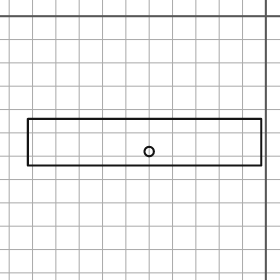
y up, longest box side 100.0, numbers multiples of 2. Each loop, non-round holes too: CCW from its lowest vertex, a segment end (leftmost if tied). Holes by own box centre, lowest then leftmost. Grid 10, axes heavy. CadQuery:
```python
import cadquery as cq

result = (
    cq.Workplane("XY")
    .moveTo(-102.0, -64.0)
    .lineTo(-2.0, -64.0)
    .lineTo(-2.0, -44.0)
    .lineTo(-102.0, -44.0)
    .close()
    .moveTo(-50.0, -58.0)
    .circle(2.0)
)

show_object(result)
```